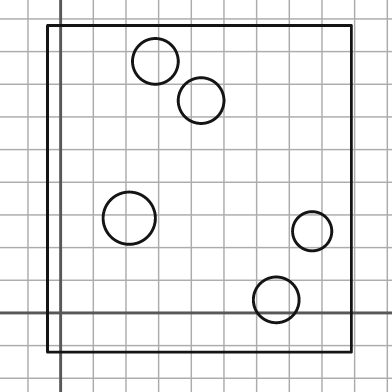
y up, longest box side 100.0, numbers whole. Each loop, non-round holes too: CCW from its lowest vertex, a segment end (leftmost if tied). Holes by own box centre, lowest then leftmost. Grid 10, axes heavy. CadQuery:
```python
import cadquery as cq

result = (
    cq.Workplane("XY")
    .moveTo(-4.0, -12.0)
    .lineTo(89.0, -12.0)
    .lineTo(89.0, 88.0)
    .lineTo(-4.0, 88.0)
    .close()
    .moveTo(66.0, 4.0)
    .circle(7.0)
    .moveTo(77.0, 25.0)
    .circle(6.0)
    .moveTo(21.0, 29.0)
    .circle(8.0)
    .moveTo(43.0, 65.0)
    .circle(7.0)
    .moveTo(29.0, 77.0)
    .circle(7.0)
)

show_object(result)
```